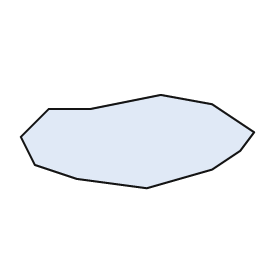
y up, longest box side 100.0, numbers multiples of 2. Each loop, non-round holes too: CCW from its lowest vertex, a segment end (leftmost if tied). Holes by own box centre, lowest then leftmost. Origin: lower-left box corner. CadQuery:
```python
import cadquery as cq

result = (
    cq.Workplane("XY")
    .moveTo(54.0, 0.0)
    .lineTo(82.0, 8.0)
    .lineTo(94.0, 16.0)
    .lineTo(100.0, 24.0)
    .lineTo(82.0, 36.0)
    .lineTo(60.0, 40.0)
    .lineTo(30.0, 34.0)
    .lineTo(12.0, 34.0)
    .lineTo(0.0, 22.0)
    .lineTo(6.0, 10.0)
    .lineTo(24.0, 4.0)
    .close()
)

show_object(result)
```